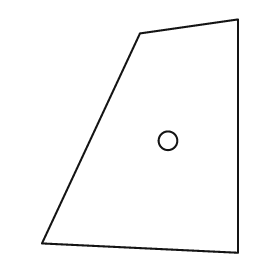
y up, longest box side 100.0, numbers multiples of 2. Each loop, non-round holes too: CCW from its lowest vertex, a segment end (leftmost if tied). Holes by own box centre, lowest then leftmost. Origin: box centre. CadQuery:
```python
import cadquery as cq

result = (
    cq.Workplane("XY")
    .moveTo(42.0, -50.0)
    .lineTo(42.0, 50.0)
    .lineTo(0.0, 44.0)
    .lineTo(-42.0, -46.0)
    .close()
    .moveTo(12.0, -2.0)
    .circle(4.0)
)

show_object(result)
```